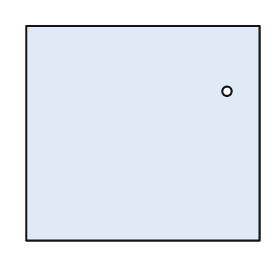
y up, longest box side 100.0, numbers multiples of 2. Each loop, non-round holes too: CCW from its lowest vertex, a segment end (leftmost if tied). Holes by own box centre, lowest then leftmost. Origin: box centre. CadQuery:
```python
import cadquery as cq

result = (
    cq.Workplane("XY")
    .moveTo(-50.0, -46.0)
    .lineTo(50.0, -46.0)
    .lineTo(50.0, 46.0)
    .lineTo(-50.0, 46.0)
    .close()
    .moveTo(36.0, 18.0)
    .circle(2.0)
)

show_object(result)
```